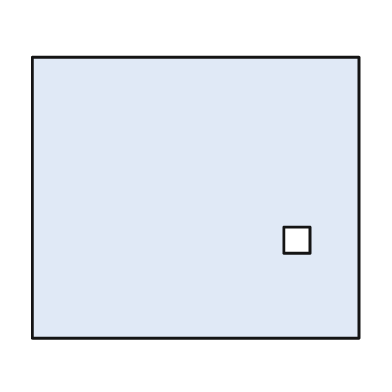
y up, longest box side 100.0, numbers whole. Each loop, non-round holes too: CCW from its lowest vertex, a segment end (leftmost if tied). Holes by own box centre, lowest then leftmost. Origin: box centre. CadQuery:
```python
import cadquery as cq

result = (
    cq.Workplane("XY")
    .moveTo(-50.0, -43.0)
    .lineTo(50.0, -43.0)
    .lineTo(50.0, 43.0)
    .lineTo(-50.0, 43.0)
    .close()
    .moveTo(27.0, -17.0)
    .lineTo(35.0, -17.0)
    .lineTo(35.0, -9.0)
    .lineTo(27.0, -9.0)
    .close()
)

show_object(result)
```